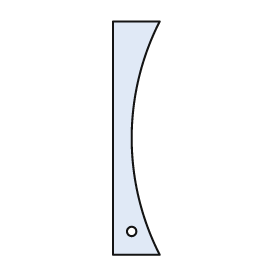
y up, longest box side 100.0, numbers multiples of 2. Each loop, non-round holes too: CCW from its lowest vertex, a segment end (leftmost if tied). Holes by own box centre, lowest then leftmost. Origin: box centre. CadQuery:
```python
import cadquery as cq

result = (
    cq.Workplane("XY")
    .moveTo(-10.0, -50.0)
    .lineTo(10.0, -50.0)
    .threePointArc((-2.0, 0.0), (10.0, 50.0))
    .lineTo(-10.0, 50.0)
    .close()
    .moveTo(-2.0, -40.0)
    .circle(2.0)
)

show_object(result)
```